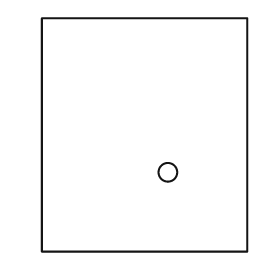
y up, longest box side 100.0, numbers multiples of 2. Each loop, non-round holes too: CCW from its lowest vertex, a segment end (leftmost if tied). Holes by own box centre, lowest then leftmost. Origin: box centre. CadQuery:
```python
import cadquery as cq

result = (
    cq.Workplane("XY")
    .moveTo(-44.0, -50.0)
    .lineTo(44.0, -50.0)
    .lineTo(44.0, 50.0)
    .lineTo(-44.0, 50.0)
    .close()
    .moveTo(10.0, -16.0)
    .circle(4.0)
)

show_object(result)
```